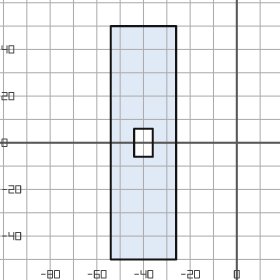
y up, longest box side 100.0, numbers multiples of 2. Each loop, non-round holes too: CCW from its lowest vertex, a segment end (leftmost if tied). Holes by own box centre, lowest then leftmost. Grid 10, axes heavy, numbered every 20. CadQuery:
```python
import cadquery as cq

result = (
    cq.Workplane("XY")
    .moveTo(-54.0, -50.0)
    .lineTo(-26.0, -50.0)
    .lineTo(-26.0, 50.0)
    .lineTo(-54.0, 50.0)
    .close()
    .moveTo(-44.0, -6.0)
    .lineTo(-36.0, -6.0)
    .lineTo(-36.0, 6.0)
    .lineTo(-44.0, 6.0)
    .close()
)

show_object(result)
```